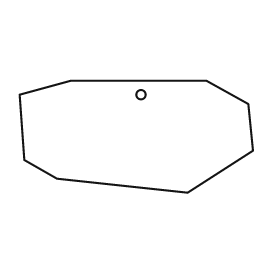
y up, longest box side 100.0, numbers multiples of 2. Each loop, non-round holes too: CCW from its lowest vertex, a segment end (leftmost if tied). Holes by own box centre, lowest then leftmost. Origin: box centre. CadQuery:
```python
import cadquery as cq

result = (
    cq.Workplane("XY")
    .moveTo(22.0, -24.0)
    .lineTo(50.0, -6.0)
    .lineTo(48.0, 14.0)
    .lineTo(30.0, 24.0)
    .lineTo(-28.0, 24.0)
    .lineTo(-50.0, 18.0)
    .lineTo(-48.0, -10.0)
    .lineTo(-34.0, -18.0)
    .close()
    .moveTo(2.0, 18.0)
    .circle(2.0)
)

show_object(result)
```